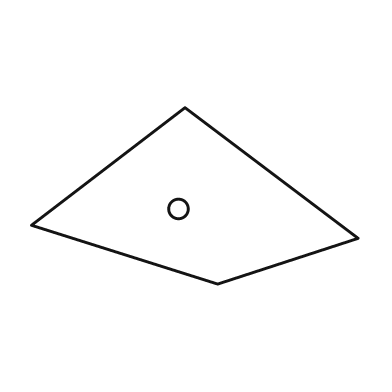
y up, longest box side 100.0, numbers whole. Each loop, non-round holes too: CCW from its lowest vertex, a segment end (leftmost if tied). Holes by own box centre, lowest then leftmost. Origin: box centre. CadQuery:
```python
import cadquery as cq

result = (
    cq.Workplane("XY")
    .moveTo(7.0, -27.0)
    .lineTo(50.0, -13.0)
    .lineTo(-3.0, 27.0)
    .lineTo(-50.0, -9.0)
    .close()
    .moveTo(-5.0, -4.0)
    .circle(3.0)
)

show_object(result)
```